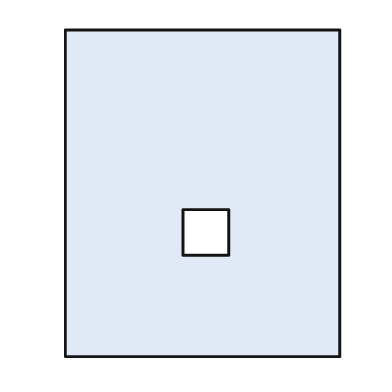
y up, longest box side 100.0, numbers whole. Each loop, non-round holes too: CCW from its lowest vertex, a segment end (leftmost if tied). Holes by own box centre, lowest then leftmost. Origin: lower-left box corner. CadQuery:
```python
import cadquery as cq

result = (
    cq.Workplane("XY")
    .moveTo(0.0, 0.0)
    .lineTo(84.0, 0.0)
    .lineTo(84.0, 100.0)
    .lineTo(0.0, 100.0)
    .close()
    .moveTo(36.0, 31.0)
    .lineTo(50.0, 31.0)
    .lineTo(50.0, 45.0)
    .lineTo(36.0, 45.0)
    .close()
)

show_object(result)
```